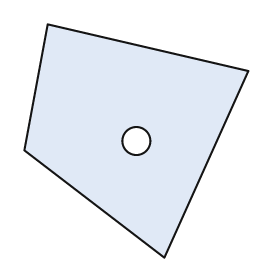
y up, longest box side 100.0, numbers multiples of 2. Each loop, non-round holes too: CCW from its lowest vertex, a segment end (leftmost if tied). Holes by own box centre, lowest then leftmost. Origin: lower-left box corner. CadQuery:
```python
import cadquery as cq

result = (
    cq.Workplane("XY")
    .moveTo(60.0, 0.0)
    .lineTo(96.0, 80.0)
    .lineTo(10.0, 100.0)
    .lineTo(0.0, 46.0)
    .close()
    .moveTo(48.0, 50.0)
    .circle(6.0)
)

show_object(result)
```